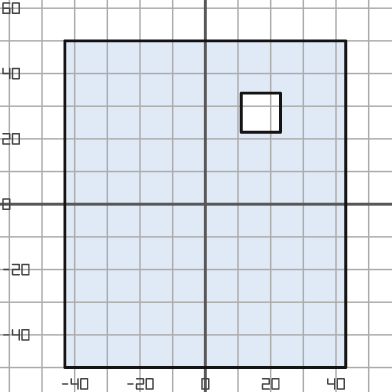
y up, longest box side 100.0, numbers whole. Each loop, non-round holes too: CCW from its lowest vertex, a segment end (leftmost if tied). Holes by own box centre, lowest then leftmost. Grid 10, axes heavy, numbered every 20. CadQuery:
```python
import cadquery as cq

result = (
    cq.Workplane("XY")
    .moveTo(-43.0, -50.0)
    .lineTo(43.0, -50.0)
    .lineTo(43.0, 50.0)
    .lineTo(-43.0, 50.0)
    .close()
    .moveTo(11.0, 22.0)
    .lineTo(23.0, 22.0)
    .lineTo(23.0, 34.0)
    .lineTo(11.0, 34.0)
    .close()
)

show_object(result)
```